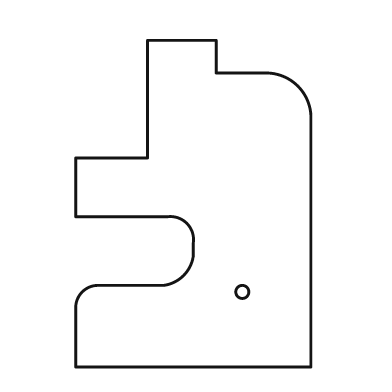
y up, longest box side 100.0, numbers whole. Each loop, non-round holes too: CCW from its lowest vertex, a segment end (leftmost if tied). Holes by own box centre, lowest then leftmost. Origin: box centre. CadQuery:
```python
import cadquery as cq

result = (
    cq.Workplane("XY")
    .moveTo(-36.0, -50.0)
    .lineTo(36.0, -50.0)
    .lineTo(36.0, 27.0)
    .threePointArc((32.0, 36.0), (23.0, 40.0))
    .lineTo(7.0, 40.0)
    .lineTo(7.0, 50.0)
    .lineTo(-14.0, 50.0)
    .lineTo(-14.0, 14.0)
    .lineTo(-36.0, 14.0)
    .lineTo(-36.0, -4.0)
    .lineTo(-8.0, -4.0)
    .threePointArc((-2.0, -6.0), (0.0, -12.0))
    .lineTo(0.0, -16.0)
    .threePointArc((-3.0, -22.0), (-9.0, -25.0))
    .lineTo(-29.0, -25.0)
    .threePointArc((-34.0, -27.0), (-36.0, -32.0))
    .close()
    .moveTo(15.0, -27.0)
    .circle(2.0)
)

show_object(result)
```